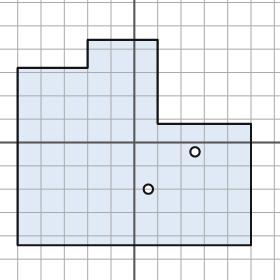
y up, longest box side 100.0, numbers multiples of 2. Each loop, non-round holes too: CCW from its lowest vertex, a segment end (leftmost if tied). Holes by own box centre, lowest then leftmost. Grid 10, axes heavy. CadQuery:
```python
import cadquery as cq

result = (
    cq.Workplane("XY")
    .moveTo(-50.0, -44.0)
    .lineTo(50.0, -44.0)
    .lineTo(50.0, 8.0)
    .lineTo(10.0, 8.0)
    .lineTo(10.0, 44.0)
    .lineTo(-20.0, 44.0)
    .lineTo(-20.0, 32.0)
    .lineTo(-50.0, 32.0)
    .close()
    .moveTo(6.0, -20.0)
    .circle(2.0)
    .moveTo(26.0, -4.0)
    .circle(2.0)
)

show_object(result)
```